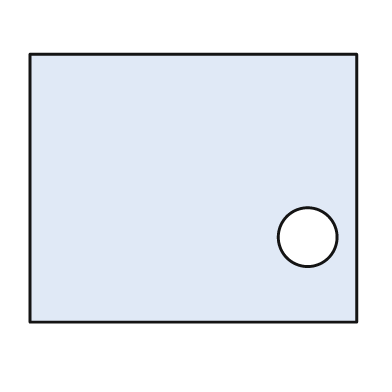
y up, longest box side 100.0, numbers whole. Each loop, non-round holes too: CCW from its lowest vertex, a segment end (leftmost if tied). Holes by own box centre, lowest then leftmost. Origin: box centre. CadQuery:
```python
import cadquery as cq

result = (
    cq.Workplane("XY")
    .moveTo(-50.0, -41.0)
    .lineTo(50.0, -41.0)
    .lineTo(50.0, 41.0)
    .lineTo(-50.0, 41.0)
    .close()
    .moveTo(35.0, -15.0)
    .circle(9.0)
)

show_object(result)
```